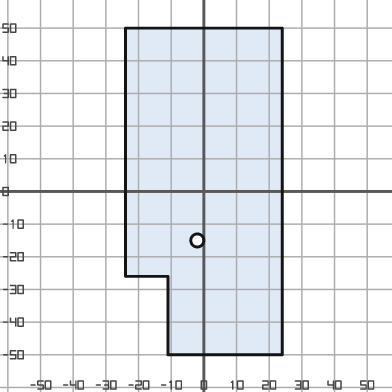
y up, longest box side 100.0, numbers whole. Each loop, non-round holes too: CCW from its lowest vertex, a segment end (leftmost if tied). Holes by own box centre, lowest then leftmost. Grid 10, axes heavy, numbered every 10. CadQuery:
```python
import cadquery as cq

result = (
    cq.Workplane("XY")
    .moveTo(-11.0, -50.0)
    .lineTo(24.0, -50.0)
    .lineTo(24.0, 50.0)
    .lineTo(-24.0, 50.0)
    .lineTo(-24.0, -26.0)
    .lineTo(-11.0, -26.0)
    .close()
    .moveTo(-2.0, -15.0)
    .circle(2.0)
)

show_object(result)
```